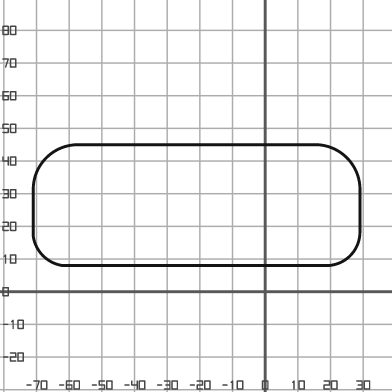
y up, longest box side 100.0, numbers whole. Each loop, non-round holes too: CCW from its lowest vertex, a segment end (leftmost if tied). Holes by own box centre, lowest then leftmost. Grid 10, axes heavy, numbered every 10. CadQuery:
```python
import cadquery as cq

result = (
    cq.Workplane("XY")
    .moveTo(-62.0, 8.0)
    .lineTo(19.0, 8.0)
    .threePointArc((26.0, 11.0), (29.0, 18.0))
    .lineTo(29.0, 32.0)
    .threePointArc((25.0, 41.0), (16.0, 45.0))
    .lineTo(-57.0, 45.0)
    .threePointArc((-67.0, 41.0), (-71.0, 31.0))
    .lineTo(-71.0, 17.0)
    .threePointArc((-68.0, 11.0), (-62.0, 8.0))
    .close()
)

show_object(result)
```